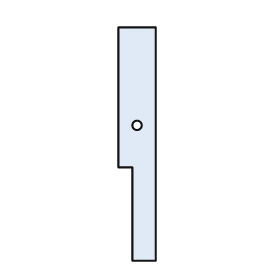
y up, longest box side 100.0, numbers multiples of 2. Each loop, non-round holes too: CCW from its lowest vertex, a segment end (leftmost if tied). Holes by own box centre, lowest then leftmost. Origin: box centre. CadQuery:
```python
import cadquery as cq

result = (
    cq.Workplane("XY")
    .moveTo(-2.0, -50.0)
    .lineTo(8.0, -50.0)
    .lineTo(8.0, 50.0)
    .lineTo(-8.0, 50.0)
    .lineTo(-8.0, -10.0)
    .lineTo(-2.0, -10.0)
    .close()
    .moveTo(0.0, 8.0)
    .circle(2.0)
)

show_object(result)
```